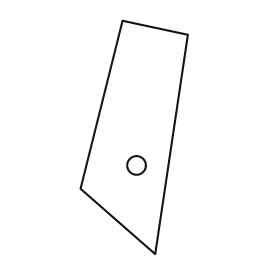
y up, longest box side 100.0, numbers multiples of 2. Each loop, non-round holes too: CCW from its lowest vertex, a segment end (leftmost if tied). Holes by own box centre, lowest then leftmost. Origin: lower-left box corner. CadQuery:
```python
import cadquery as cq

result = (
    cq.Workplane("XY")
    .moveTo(32.0, 0.0)
    .lineTo(46.0, 94.0)
    .lineTo(18.0, 100.0)
    .lineTo(0.0, 28.0)
    .close()
    .moveTo(24.0, 38.0)
    .circle(4.0)
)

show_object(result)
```